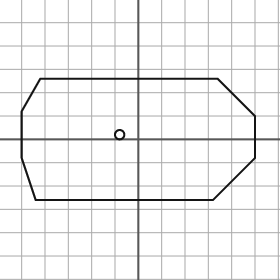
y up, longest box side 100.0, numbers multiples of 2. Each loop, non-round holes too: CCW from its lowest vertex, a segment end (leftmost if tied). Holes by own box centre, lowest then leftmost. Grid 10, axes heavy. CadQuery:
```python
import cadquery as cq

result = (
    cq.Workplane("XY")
    .moveTo(-44.0, -26.0)
    .lineTo(32.0, -26.0)
    .lineTo(50.0, -8.0)
    .lineTo(50.0, 10.0)
    .lineTo(34.0, 26.0)
    .lineTo(-42.0, 26.0)
    .lineTo(-50.0, 12.0)
    .lineTo(-50.0, -8.0)
    .close()
    .moveTo(-8.0, 2.0)
    .circle(2.0)
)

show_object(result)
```